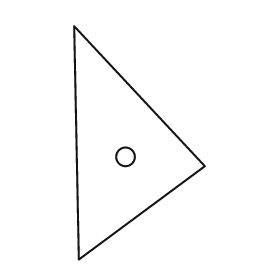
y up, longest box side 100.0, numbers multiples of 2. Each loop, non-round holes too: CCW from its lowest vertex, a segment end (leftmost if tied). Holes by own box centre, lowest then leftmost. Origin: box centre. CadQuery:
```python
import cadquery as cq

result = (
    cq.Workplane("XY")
    .moveTo(-26.0, -50.0)
    .lineTo(28.0, -10.0)
    .lineTo(-28.0, 50.0)
    .close()
    .moveTo(-6.0, -6.0)
    .circle(4.0)
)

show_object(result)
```